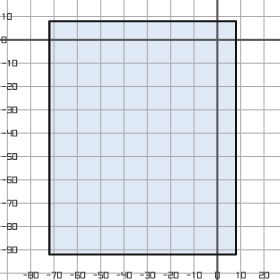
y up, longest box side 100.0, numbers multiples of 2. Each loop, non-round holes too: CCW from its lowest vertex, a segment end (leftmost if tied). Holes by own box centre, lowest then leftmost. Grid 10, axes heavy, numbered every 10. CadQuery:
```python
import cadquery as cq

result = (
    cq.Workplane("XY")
    .moveTo(-72.0, -92.0)
    .lineTo(8.0, -92.0)
    .lineTo(8.0, 8.0)
    .lineTo(-72.0, 8.0)
    .close()
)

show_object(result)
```